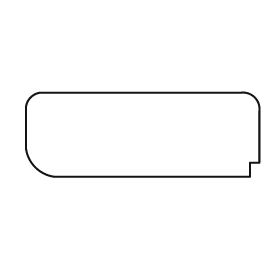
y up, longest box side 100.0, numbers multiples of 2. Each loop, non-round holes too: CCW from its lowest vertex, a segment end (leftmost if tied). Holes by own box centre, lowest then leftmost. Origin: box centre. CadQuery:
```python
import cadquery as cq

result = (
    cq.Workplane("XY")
    .moveTo(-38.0, -18.0)
    .lineTo(46.0, -18.0)
    .lineTo(46.0, -12.0)
    .lineTo(50.0, -12.0)
    .lineTo(50.0, 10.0)
    .threePointArc((48.0, 16.0), (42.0, 18.0))
    .lineTo(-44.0, 18.0)
    .threePointArc((-48.0, 16.0), (-50.0, 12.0))
    .lineTo(-50.0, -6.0)
    .threePointArc((-46.0, -14.0), (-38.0, -18.0))
    .close()
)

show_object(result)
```